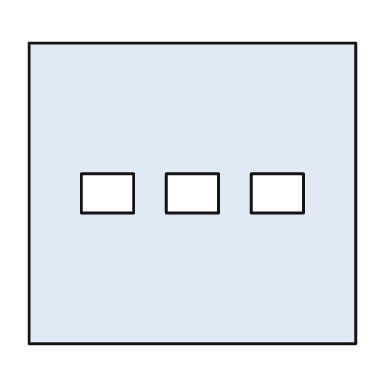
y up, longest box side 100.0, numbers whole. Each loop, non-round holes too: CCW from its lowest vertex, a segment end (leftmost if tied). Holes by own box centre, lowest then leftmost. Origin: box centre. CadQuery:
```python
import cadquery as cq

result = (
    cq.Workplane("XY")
    .moveTo(-50.0, -46.0)
    .lineTo(50.0, -46.0)
    .lineTo(50.0, 46.0)
    .lineTo(-50.0, 46.0)
    .close()
    .moveTo(-34.0, -6.0)
    .lineTo(-18.0, -6.0)
    .lineTo(-18.0, 6.0)
    .lineTo(-34.0, 6.0)
    .close()
    .moveTo(-8.0, -6.0)
    .lineTo(8.0, -6.0)
    .lineTo(8.0, 6.0)
    .lineTo(-8.0, 6.0)
    .close()
    .moveTo(18.0, -6.0)
    .lineTo(34.0, -6.0)
    .lineTo(34.0, 6.0)
    .lineTo(18.0, 6.0)
    .close()
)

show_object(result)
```